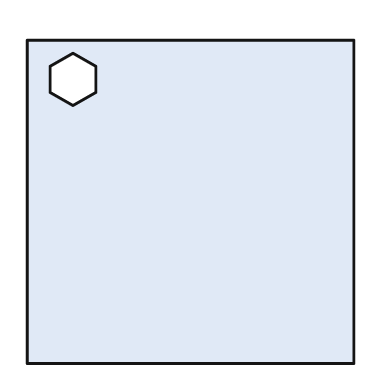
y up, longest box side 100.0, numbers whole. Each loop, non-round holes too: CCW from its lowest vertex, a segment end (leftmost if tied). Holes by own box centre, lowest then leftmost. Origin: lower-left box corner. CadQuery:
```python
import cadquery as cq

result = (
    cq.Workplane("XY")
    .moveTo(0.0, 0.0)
    .lineTo(100.0, 0.0)
    .lineTo(100.0, 99.0)
    .lineTo(0.0, 99.0)
    .close()
    .moveTo(14.0, 79.0)
    .lineTo(21.0, 83.0)
    .lineTo(21.0, 91.0)
    .lineTo(14.0, 95.0)
    .lineTo(7.0, 91.0)
    .lineTo(7.0, 83.0)
    .close()
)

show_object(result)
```